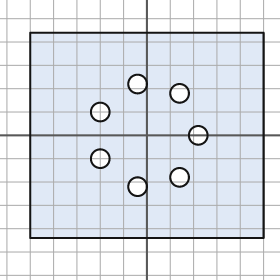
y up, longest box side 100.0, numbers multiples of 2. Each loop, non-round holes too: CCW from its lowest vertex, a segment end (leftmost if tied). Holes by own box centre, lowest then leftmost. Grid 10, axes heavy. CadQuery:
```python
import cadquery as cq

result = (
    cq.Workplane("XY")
    .moveTo(-50.0, -44.0)
    .lineTo(50.0, -44.0)
    .lineTo(50.0, 44.0)
    .lineTo(-50.0, 44.0)
    .close()
    .moveTo(-4.0, -22.0)
    .circle(4.0)
    .moveTo(14.0, -18.0)
    .circle(4.0)
    .moveTo(-20.0, -10.0)
    .circle(4.0)
    .moveTo(22.0, 0.0)
    .circle(4.0)
    .moveTo(-20.0, 10.0)
    .circle(4.0)
    .moveTo(14.0, 18.0)
    .circle(4.0)
    .moveTo(-4.0, 22.0)
    .circle(4.0)
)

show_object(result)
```